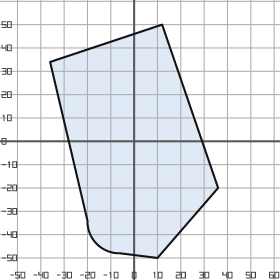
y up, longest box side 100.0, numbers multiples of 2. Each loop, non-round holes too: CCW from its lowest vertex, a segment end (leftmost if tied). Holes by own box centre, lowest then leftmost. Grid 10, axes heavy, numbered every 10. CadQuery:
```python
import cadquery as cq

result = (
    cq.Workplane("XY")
    .moveTo(10.0, -50.0)
    .lineTo(36.0, -20.0)
    .lineTo(12.0, 50.0)
    .lineTo(-36.0, 34.0)
    .lineTo(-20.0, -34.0)
    .threePointArc((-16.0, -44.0), (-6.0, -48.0))
    .close()
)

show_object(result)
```